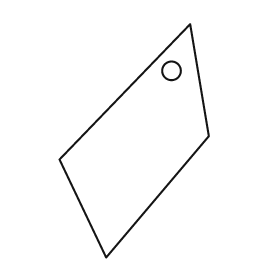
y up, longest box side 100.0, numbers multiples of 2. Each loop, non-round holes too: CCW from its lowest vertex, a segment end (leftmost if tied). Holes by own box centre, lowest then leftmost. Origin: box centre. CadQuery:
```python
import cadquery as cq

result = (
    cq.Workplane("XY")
    .moveTo(-12.0, -50.0)
    .lineTo(32.0, 2.0)
    .lineTo(24.0, 50.0)
    .lineTo(-32.0, -8.0)
    .close()
    .moveTo(16.0, 30.0)
    .circle(4.0)
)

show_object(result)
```